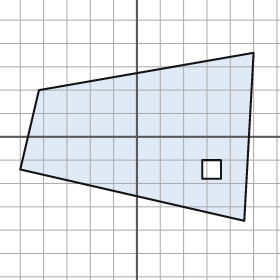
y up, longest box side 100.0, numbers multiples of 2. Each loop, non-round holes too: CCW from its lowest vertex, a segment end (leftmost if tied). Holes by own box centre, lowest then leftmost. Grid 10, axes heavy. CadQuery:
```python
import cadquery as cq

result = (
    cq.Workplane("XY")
    .moveTo(46.0, -36.0)
    .lineTo(50.0, 36.0)
    .lineTo(-42.0, 20.0)
    .lineTo(-50.0, -14.0)
    .close()
    .moveTo(28.0, -18.0)
    .lineTo(36.0, -18.0)
    .lineTo(36.0, -10.0)
    .lineTo(28.0, -10.0)
    .close()
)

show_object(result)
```